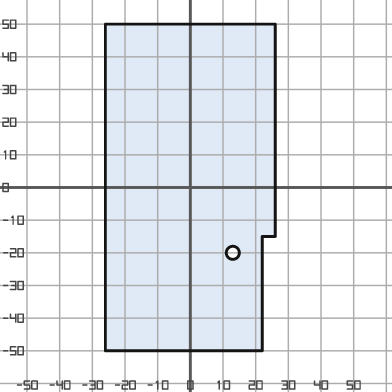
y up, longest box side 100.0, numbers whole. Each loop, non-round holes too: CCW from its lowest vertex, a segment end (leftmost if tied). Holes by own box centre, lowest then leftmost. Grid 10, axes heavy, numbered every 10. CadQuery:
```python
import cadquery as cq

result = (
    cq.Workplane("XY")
    .moveTo(-26.0, -50.0)
    .lineTo(22.0, -50.0)
    .lineTo(22.0, -15.0)
    .lineTo(26.0, -15.0)
    .lineTo(26.0, 50.0)
    .lineTo(-26.0, 50.0)
    .close()
    .moveTo(13.0, -20.0)
    .circle(2.0)
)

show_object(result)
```